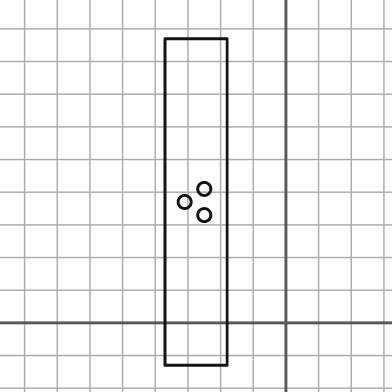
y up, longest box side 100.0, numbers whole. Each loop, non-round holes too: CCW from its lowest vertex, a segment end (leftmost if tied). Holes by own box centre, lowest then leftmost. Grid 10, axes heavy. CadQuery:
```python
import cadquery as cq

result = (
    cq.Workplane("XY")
    .moveTo(-37.0, -13.0)
    .lineTo(-18.0, -13.0)
    .lineTo(-18.0, 87.0)
    .lineTo(-37.0, 87.0)
    .close()
    .moveTo(-25.0, 33.0)
    .circle(2.0)
    .moveTo(-31.0, 37.0)
    .circle(2.0)
    .moveTo(-25.0, 41.0)
    .circle(2.0)
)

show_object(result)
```